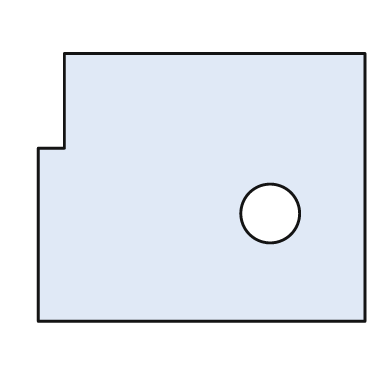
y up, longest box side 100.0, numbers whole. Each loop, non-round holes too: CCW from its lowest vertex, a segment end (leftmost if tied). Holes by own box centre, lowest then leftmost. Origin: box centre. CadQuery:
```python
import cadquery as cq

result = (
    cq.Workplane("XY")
    .moveTo(-50.0, -41.0)
    .lineTo(50.0, -41.0)
    .lineTo(50.0, 41.0)
    .lineTo(-42.0, 41.0)
    .lineTo(-42.0, 12.0)
    .lineTo(-50.0, 12.0)
    .close()
    .moveTo(21.0, -8.0)
    .circle(9.0)
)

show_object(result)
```